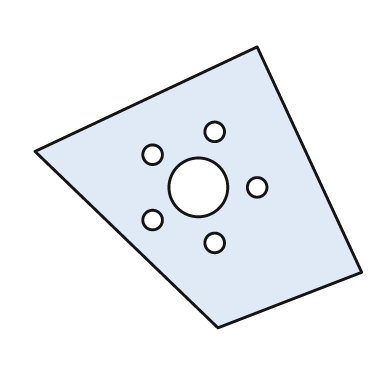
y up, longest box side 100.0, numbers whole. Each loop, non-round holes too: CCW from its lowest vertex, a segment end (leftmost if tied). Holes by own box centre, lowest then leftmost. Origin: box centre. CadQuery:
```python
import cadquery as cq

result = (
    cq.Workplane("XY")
    .moveTo(6.0, -43.0)
    .lineTo(50.0, -26.0)
    .lineTo(18.0, 43.0)
    .lineTo(-50.0, 11.0)
    .close()
    .moveTo(5.0, -17.0)
    .circle(3.0)
    .moveTo(-14.0, -10.0)
    .circle(3.0)
    .moveTo(0.0, 0.0)
    .circle(9.0)
    .moveTo(18.0, 0.0)
    .circle(3.0)
    .moveTo(-14.0, 10.0)
    .circle(3.0)
    .moveTo(5.0, 17.0)
    .circle(3.0)
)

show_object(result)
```